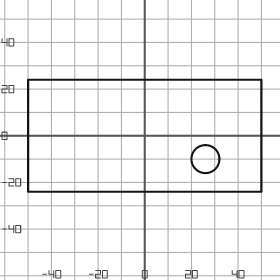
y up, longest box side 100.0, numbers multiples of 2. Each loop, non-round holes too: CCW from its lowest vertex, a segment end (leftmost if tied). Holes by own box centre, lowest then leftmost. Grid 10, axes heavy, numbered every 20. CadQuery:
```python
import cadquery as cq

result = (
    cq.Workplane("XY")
    .moveTo(-50.0, -24.0)
    .lineTo(50.0, -24.0)
    .lineTo(50.0, 24.0)
    .lineTo(-50.0, 24.0)
    .close()
    .moveTo(26.0, -10.0)
    .circle(6.0)
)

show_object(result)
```